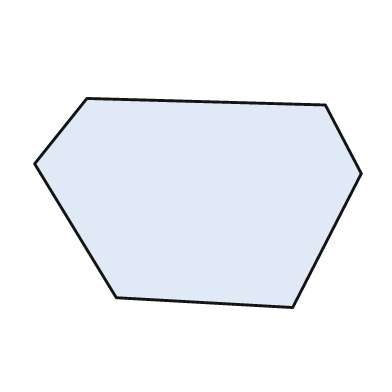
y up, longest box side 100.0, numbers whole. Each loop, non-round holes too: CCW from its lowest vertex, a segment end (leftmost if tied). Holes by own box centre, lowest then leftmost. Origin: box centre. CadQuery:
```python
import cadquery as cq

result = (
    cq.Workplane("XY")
    .moveTo(29.0, -32.0)
    .lineTo(50.0, 9.0)
    .lineTo(39.0, 30.0)
    .lineTo(-34.0, 32.0)
    .lineTo(-50.0, 12.0)
    .lineTo(-25.0, -29.0)
    .close()
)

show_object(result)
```